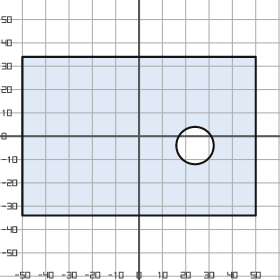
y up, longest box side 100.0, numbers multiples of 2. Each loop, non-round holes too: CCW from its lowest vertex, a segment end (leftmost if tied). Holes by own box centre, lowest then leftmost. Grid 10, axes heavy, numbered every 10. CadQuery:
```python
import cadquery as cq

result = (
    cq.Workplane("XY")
    .moveTo(-50.0, -34.0)
    .lineTo(50.0, -34.0)
    .lineTo(50.0, 34.0)
    .lineTo(-50.0, 34.0)
    .close()
    .moveTo(24.0, -4.0)
    .circle(8.0)
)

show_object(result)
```